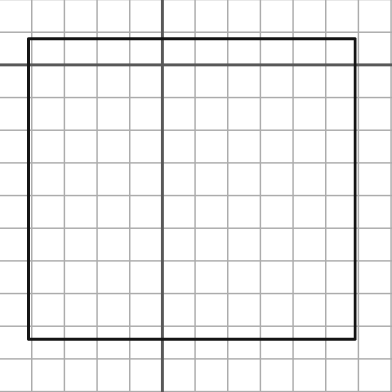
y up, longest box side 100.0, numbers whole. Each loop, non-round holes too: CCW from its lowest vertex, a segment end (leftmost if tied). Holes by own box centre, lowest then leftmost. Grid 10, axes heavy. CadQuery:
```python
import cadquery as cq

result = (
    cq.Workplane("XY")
    .moveTo(-41.0, -84.0)
    .lineTo(59.0, -84.0)
    .lineTo(59.0, 8.0)
    .lineTo(-41.0, 8.0)
    .close()
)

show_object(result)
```